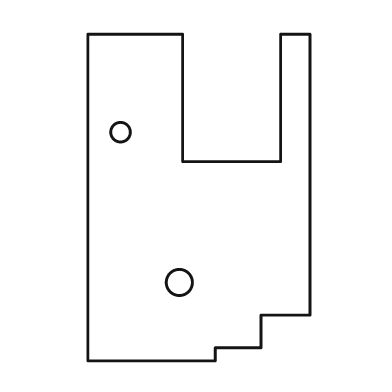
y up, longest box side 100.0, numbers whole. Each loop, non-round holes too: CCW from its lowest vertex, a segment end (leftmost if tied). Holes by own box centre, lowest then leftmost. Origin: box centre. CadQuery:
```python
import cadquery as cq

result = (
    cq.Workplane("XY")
    .moveTo(-34.0, -50.0)
    .lineTo(5.0, -50.0)
    .lineTo(5.0, -46.0)
    .lineTo(19.0, -46.0)
    .lineTo(19.0, -36.0)
    .lineTo(34.0, -36.0)
    .lineTo(34.0, 50.0)
    .lineTo(25.0, 50.0)
    .lineTo(25.0, 11.0)
    .lineTo(-5.0, 11.0)
    .lineTo(-5.0, 50.0)
    .lineTo(-34.0, 50.0)
    .close()
    .moveTo(-6.0, -26.0)
    .circle(4.0)
    .moveTo(-24.0, 20.0)
    .circle(3.0)
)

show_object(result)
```